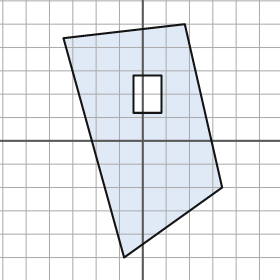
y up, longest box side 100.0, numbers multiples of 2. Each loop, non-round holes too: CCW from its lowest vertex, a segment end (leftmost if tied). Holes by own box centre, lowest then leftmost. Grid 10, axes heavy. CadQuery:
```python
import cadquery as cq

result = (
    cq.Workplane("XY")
    .moveTo(-8.0, -50.0)
    .lineTo(34.0, -20.0)
    .lineTo(18.0, 50.0)
    .lineTo(-34.0, 44.0)
    .close()
    .moveTo(-4.0, 12.0)
    .lineTo(8.0, 12.0)
    .lineTo(8.0, 28.0)
    .lineTo(-4.0, 28.0)
    .close()
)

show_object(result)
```